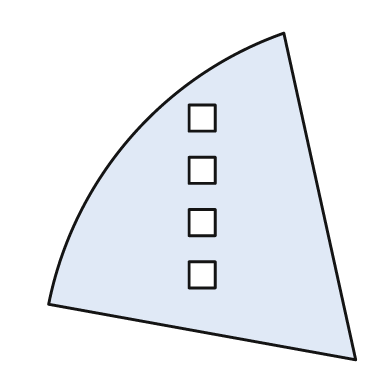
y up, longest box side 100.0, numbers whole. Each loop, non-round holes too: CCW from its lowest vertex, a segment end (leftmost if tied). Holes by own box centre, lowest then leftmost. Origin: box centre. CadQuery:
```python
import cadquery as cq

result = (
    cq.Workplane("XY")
    .moveTo(47.0, -50.0)
    .lineTo(25.0, 50.0)
    .threePointArc((-22.0, 18.0), (-47.0, -33.0))
    .close()
    .moveTo(-4.0, -28.0)
    .lineTo(4.0, -28.0)
    .lineTo(4.0, -20.0)
    .lineTo(-4.0, -20.0)
    .close()
    .moveTo(-4.0, -12.0)
    .lineTo(4.0, -12.0)
    .lineTo(4.0, -4.0)
    .lineTo(-4.0, -4.0)
    .close()
    .moveTo(-4.0, 4.0)
    .lineTo(4.0, 4.0)
    .lineTo(4.0, 12.0)
    .lineTo(-4.0, 12.0)
    .close()
    .moveTo(-4.0, 20.0)
    .lineTo(4.0, 20.0)
    .lineTo(4.0, 28.0)
    .lineTo(-4.0, 28.0)
    .close()
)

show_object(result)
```